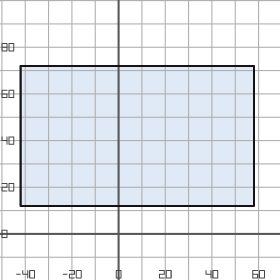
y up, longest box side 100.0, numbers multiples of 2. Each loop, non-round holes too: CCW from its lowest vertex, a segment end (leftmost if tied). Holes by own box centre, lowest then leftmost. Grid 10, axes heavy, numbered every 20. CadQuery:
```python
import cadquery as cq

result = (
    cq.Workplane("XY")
    .moveTo(-42.0, 12.0)
    .lineTo(58.0, 12.0)
    .lineTo(58.0, 72.0)
    .lineTo(-42.0, 72.0)
    .close()
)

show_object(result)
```